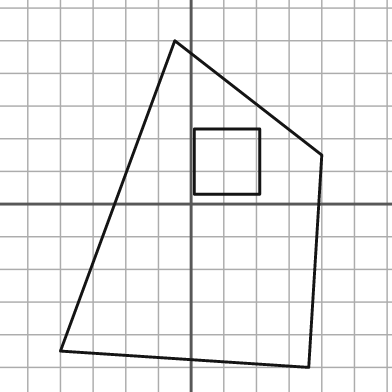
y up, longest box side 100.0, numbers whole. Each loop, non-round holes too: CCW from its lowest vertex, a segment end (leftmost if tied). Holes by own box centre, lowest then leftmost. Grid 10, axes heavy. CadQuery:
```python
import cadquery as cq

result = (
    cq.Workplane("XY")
    .moveTo(36.0, -50.0)
    .lineTo(40.0, 15.0)
    .lineTo(-5.0, 50.0)
    .lineTo(-40.0, -45.0)
    .close()
    .moveTo(1.0, 3.0)
    .lineTo(21.0, 3.0)
    .lineTo(21.0, 23.0)
    .lineTo(1.0, 23.0)
    .close()
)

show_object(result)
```